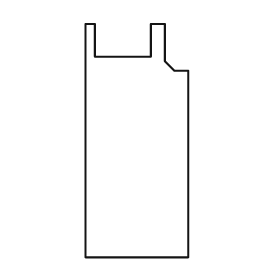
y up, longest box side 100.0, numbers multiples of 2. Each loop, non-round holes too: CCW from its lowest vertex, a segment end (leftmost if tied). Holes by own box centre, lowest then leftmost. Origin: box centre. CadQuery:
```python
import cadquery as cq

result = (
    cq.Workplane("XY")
    .moveTo(-22.0, -50.0)
    .lineTo(22.0, -50.0)
    .lineTo(22.0, 30.0)
    .lineTo(16.0, 30.0)
    .lineTo(12.0, 34.0)
    .lineTo(12.0, 50.0)
    .lineTo(6.0, 50.0)
    .lineTo(6.0, 36.0)
    .lineTo(-18.0, 36.0)
    .lineTo(-18.0, 50.0)
    .lineTo(-22.0, 50.0)
    .close()
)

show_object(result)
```